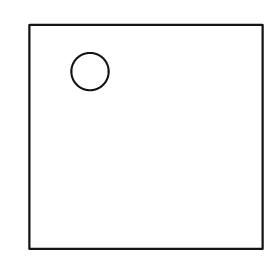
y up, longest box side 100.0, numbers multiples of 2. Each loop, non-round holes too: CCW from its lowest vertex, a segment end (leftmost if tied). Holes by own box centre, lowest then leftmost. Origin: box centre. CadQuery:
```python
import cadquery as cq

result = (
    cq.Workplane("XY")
    .moveTo(-50.0, -48.0)
    .lineTo(50.0, -48.0)
    .lineTo(50.0, 48.0)
    .lineTo(-50.0, 48.0)
    .close()
    .moveTo(-24.0, 28.0)
    .circle(8.0)
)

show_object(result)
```